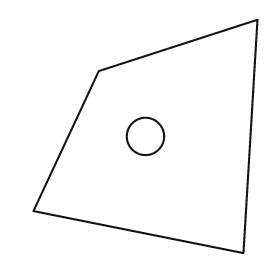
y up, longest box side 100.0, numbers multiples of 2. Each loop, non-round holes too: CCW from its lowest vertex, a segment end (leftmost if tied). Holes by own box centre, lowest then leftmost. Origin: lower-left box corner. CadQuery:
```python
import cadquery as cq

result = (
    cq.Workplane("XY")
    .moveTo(90.0, 0.0)
    .lineTo(96.0, 100.0)
    .lineTo(28.0, 78.0)
    .lineTo(0.0, 18.0)
    .close()
    .moveTo(48.0, 50.0)
    .circle(8.0)
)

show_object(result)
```